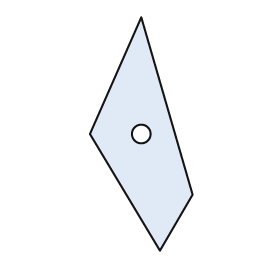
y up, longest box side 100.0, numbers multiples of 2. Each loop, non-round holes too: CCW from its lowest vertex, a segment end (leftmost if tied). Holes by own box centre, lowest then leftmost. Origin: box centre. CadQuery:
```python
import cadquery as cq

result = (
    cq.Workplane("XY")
    .moveTo(8.0, -50.0)
    .lineTo(22.0, -26.0)
    .lineTo(0.0, 50.0)
    .lineTo(-22.0, 0.0)
    .close()
    .moveTo(0.0, 0.0)
    .circle(4.0)
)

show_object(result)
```